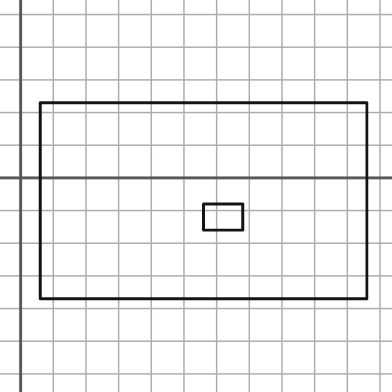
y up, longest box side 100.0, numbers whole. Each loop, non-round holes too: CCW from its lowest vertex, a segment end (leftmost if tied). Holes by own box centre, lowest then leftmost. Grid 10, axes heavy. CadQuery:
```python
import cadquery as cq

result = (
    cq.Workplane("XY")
    .moveTo(6.0, -37.0)
    .lineTo(106.0, -37.0)
    .lineTo(106.0, 23.0)
    .lineTo(6.0, 23.0)
    .close()
    .moveTo(56.0, -16.0)
    .lineTo(68.0, -16.0)
    .lineTo(68.0, -8.0)
    .lineTo(56.0, -8.0)
    .close()
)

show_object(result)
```